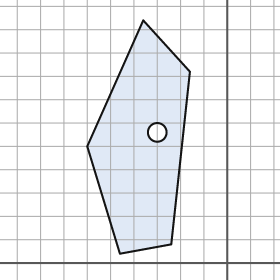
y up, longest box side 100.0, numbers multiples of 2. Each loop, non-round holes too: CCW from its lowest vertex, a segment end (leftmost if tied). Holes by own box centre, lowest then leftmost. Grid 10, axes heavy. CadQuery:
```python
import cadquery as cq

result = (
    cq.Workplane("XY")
    .moveTo(-46.0, 4.0)
    .lineTo(-24.0, 8.0)
    .lineTo(-16.0, 82.0)
    .lineTo(-36.0, 104.0)
    .lineTo(-60.0, 50.0)
    .close()
    .moveTo(-30.0, 56.0)
    .circle(4.0)
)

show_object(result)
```